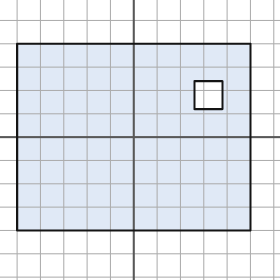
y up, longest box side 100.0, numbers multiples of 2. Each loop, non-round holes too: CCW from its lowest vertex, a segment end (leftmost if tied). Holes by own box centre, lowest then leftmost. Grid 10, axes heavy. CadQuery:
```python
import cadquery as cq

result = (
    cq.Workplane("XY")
    .moveTo(-50.0, -40.0)
    .lineTo(50.0, -40.0)
    .lineTo(50.0, 40.0)
    .lineTo(-50.0, 40.0)
    .close()
    .moveTo(26.0, 12.0)
    .lineTo(38.0, 12.0)
    .lineTo(38.0, 24.0)
    .lineTo(26.0, 24.0)
    .close()
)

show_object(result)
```